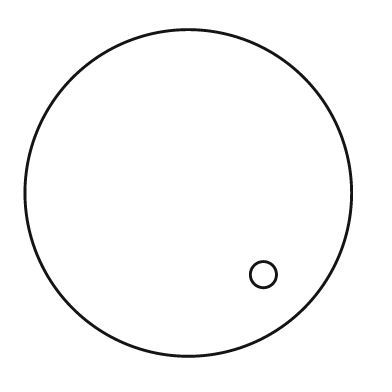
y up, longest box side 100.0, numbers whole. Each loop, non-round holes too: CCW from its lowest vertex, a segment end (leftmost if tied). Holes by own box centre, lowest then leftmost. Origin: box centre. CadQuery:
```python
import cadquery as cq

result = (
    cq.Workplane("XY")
    .moveTo(0.0, 0.0)
    .circle(50.0)
    .moveTo(23.0, -25.0)
    .circle(4.0)
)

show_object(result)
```